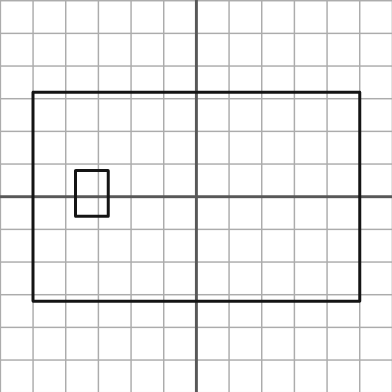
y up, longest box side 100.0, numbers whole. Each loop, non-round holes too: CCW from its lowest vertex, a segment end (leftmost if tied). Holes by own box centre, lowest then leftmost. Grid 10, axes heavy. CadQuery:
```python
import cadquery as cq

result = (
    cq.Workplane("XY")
    .moveTo(-50.0, -32.0)
    .lineTo(50.0, -32.0)
    .lineTo(50.0, 32.0)
    .lineTo(-50.0, 32.0)
    .close()
    .moveTo(-37.0, -6.0)
    .lineTo(-27.0, -6.0)
    .lineTo(-27.0, 8.0)
    .lineTo(-37.0, 8.0)
    .close()
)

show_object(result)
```